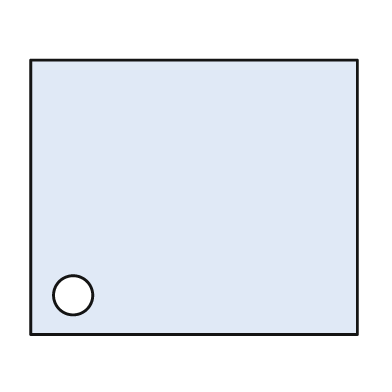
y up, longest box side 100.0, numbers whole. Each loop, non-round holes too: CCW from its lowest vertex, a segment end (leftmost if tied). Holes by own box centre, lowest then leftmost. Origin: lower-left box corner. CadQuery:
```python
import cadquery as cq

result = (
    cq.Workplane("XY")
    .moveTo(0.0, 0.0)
    .lineTo(100.0, 0.0)
    .lineTo(100.0, 84.0)
    .lineTo(0.0, 84.0)
    .close()
    .moveTo(13.0, 12.0)
    .circle(6.0)
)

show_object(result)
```